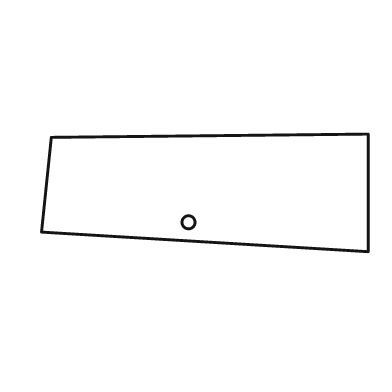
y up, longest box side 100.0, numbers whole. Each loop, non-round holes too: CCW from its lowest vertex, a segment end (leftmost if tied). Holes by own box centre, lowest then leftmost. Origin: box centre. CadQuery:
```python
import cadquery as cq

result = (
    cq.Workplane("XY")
    .moveTo(50.0, -18.0)
    .lineTo(50.0, 18.0)
    .lineTo(-47.0, 17.0)
    .lineTo(-50.0, -12.0)
    .close()
    .moveTo(-5.0, -9.0)
    .circle(2.0)
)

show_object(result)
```